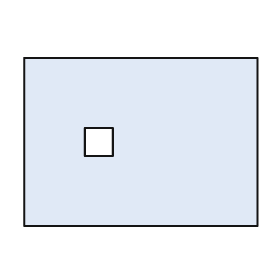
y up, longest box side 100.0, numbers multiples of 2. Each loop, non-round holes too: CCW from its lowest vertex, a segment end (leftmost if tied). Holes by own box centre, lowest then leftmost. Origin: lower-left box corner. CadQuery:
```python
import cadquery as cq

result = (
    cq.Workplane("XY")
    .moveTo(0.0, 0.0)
    .lineTo(100.0, 0.0)
    .lineTo(100.0, 72.0)
    .lineTo(0.0, 72.0)
    .close()
    .moveTo(26.0, 30.0)
    .lineTo(38.0, 30.0)
    .lineTo(38.0, 42.0)
    .lineTo(26.0, 42.0)
    .close()
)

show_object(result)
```